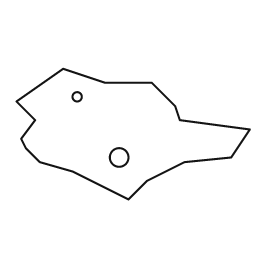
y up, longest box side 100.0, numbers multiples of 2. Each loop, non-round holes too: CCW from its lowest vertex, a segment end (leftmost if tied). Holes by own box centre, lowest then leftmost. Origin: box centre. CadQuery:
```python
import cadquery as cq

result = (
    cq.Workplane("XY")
    .moveTo(-2.0, -28.0)
    .lineTo(6.0, -20.0)
    .lineTo(22.0, -12.0)
    .lineTo(42.0, -10.0)
    .lineTo(50.0, 2.0)
    .lineTo(20.0, 6.0)
    .lineTo(18.0, 12.0)
    .lineTo(8.0, 22.0)
    .lineTo(-12.0, 22.0)
    .lineTo(-30.0, 28.0)
    .lineTo(-50.0, 14.0)
    .lineTo(-42.0, 6.0)
    .lineTo(-48.0, -2.0)
    .lineTo(-46.0, -6.0)
    .lineTo(-40.0, -12.0)
    .lineTo(-26.0, -16.0)
    .close()
    .moveTo(-6.0, -10.0)
    .circle(4.0)
    .moveTo(-24.0, 16.0)
    .circle(2.0)
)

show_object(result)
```